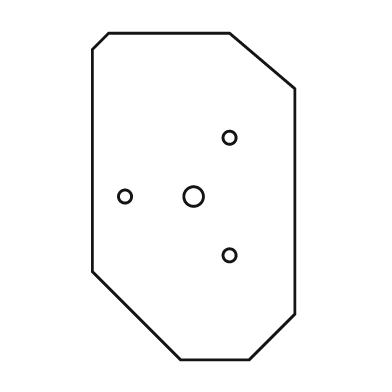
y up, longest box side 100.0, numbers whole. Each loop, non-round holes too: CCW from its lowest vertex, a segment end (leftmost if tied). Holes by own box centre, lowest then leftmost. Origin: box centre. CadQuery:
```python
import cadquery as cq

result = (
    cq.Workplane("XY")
    .moveTo(-4.0, -50.0)
    .lineTo(17.0, -50.0)
    .lineTo(31.0, -36.0)
    .lineTo(31.0, 33.0)
    .lineTo(11.0, 50.0)
    .lineTo(-26.0, 50.0)
    .lineTo(-31.0, 45.0)
    .lineTo(-31.0, -23.0)
    .close()
    .moveTo(11.0, -18.0)
    .circle(2.0)
    .moveTo(-21.0, 0.0)
    .circle(2.0)
    .moveTo(0.0, 0.0)
    .circle(3.0)
    .moveTo(11.0, 18.0)
    .circle(2.0)
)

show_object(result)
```